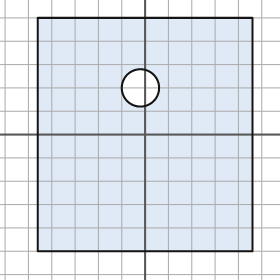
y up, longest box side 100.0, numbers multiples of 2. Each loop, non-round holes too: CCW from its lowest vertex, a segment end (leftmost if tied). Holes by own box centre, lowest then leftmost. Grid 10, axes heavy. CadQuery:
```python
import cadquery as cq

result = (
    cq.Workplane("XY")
    .moveTo(-46.0, -50.0)
    .lineTo(46.0, -50.0)
    .lineTo(46.0, 50.0)
    .lineTo(-46.0, 50.0)
    .close()
    .moveTo(-2.0, 20.0)
    .circle(8.0)
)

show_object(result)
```